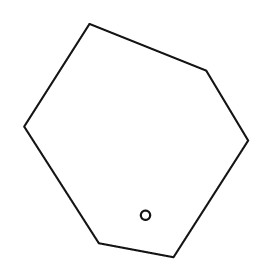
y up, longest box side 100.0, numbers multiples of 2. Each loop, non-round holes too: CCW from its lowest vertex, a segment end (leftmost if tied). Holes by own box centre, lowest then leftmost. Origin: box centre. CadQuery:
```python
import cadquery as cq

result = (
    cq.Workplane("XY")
    .moveTo(16.0, -50.0)
    .lineTo(48.0, 0.0)
    .lineTo(30.0, 30.0)
    .lineTo(-20.0, 50.0)
    .lineTo(-48.0, 6.0)
    .lineTo(-16.0, -44.0)
    .close()
    .moveTo(4.0, -32.0)
    .circle(2.0)
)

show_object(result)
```